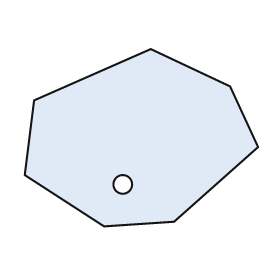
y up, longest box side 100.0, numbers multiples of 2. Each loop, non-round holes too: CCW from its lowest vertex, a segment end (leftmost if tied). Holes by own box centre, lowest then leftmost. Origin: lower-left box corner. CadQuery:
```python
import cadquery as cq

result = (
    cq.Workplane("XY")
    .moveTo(34.0, 0.0)
    .lineTo(64.0, 2.0)
    .lineTo(100.0, 34.0)
    .lineTo(88.0, 60.0)
    .lineTo(54.0, 76.0)
    .lineTo(4.0, 54.0)
    .lineTo(0.0, 22.0)
    .close()
    .moveTo(42.0, 18.0)
    .circle(4.0)
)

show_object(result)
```